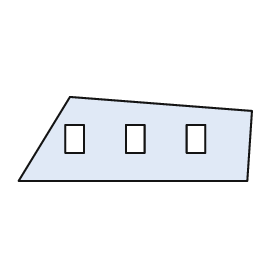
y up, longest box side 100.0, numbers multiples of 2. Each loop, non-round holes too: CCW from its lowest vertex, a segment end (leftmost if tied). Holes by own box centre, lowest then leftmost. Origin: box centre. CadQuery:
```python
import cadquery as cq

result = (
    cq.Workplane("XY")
    .moveTo(-50.0, -18.0)
    .lineTo(48.0, -18.0)
    .lineTo(50.0, 12.0)
    .lineTo(-28.0, 18.0)
    .close()
    .moveTo(-30.0, -6.0)
    .lineTo(-22.0, -6.0)
    .lineTo(-22.0, 6.0)
    .lineTo(-30.0, 6.0)
    .close()
    .moveTo(-4.0, -6.0)
    .lineTo(4.0, -6.0)
    .lineTo(4.0, 6.0)
    .lineTo(-4.0, 6.0)
    .close()
    .moveTo(22.0, -6.0)
    .lineTo(30.0, -6.0)
    .lineTo(30.0, 6.0)
    .lineTo(22.0, 6.0)
    .close()
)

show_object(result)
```